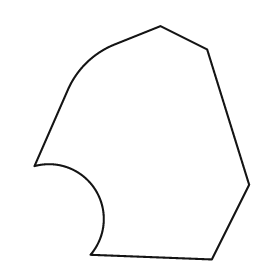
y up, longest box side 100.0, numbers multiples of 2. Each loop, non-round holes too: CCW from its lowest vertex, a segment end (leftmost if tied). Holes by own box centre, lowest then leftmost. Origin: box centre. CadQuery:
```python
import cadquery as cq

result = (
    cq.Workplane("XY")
    .moveTo(30.0, -50.0)
    .lineTo(46.0, -18.0)
    .lineTo(28.0, 40.0)
    .lineTo(8.0, 50.0)
    .lineTo(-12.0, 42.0)
    .threePointArc((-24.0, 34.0), (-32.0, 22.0))
    .lineTo(-46.0, -10.0)
    .threePointArc((-20.0, -20.0), (-22.0, -48.0))
    .close()
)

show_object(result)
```